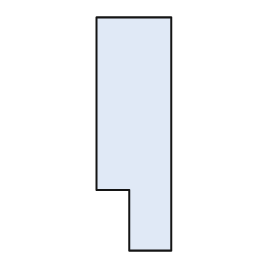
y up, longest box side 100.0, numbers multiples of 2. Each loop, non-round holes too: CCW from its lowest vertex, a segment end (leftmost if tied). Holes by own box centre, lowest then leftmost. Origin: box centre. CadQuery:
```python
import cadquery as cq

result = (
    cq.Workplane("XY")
    .moveTo(-2.0, -50.0)
    .lineTo(16.0, -50.0)
    .lineTo(16.0, 50.0)
    .lineTo(-16.0, 50.0)
    .lineTo(-16.0, -24.0)
    .lineTo(-2.0, -24.0)
    .close()
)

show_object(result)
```